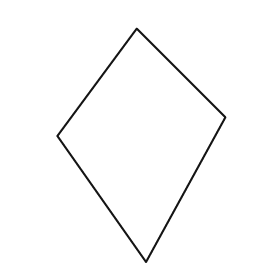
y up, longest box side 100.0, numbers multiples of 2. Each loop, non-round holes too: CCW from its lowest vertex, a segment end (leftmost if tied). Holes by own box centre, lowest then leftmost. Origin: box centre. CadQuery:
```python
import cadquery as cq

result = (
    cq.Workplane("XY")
    .moveTo(2.0, -50.0)
    .lineTo(36.0, 12.0)
    .lineTo(-2.0, 50.0)
    .lineTo(-36.0, 4.0)
    .close()
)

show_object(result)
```